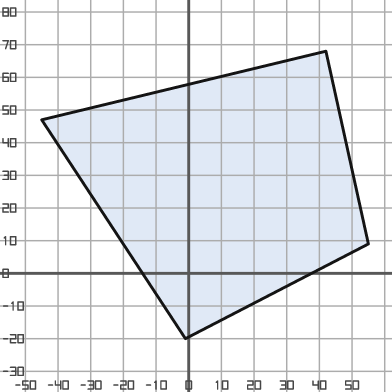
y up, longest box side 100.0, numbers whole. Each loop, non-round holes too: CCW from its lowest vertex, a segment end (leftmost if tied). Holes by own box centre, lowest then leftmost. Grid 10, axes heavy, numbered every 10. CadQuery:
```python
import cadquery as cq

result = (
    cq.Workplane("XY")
    .moveTo(-1.0, -20.0)
    .lineTo(55.0, 9.0)
    .lineTo(42.0, 68.0)
    .lineTo(-45.0, 47.0)
    .close()
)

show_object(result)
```